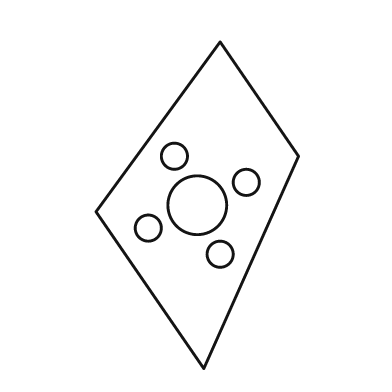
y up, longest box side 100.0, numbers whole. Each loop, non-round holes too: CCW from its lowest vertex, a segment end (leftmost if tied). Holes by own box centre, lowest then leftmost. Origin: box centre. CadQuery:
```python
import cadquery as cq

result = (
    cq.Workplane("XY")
    .moveTo(2.0, -50.0)
    .lineTo(31.0, 15.0)
    .lineTo(7.0, 50.0)
    .lineTo(-31.0, -2.0)
    .close()
    .moveTo(7.0, -15.0)
    .circle(4.0)
    .moveTo(-15.0, -7.0)
    .circle(4.0)
    .moveTo(0.0, 0.0)
    .circle(9.0)
    .moveTo(15.0, 7.0)
    .circle(4.0)
    .moveTo(-7.0, 15.0)
    .circle(4.0)
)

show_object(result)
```